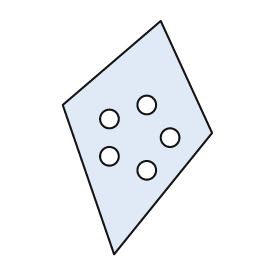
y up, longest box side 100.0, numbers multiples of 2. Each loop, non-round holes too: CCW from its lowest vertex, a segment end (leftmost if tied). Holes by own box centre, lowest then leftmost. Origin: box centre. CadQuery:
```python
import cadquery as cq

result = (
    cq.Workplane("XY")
    .moveTo(-10.0, -50.0)
    .lineTo(32.0, 2.0)
    .lineTo(10.0, 50.0)
    .lineTo(-32.0, 14.0)
    .close()
    .moveTo(4.0, -14.0)
    .circle(4.0)
    .moveTo(-12.0, -8.0)
    .circle(4.0)
    .moveTo(14.0, 0.0)
    .circle(4.0)
    .moveTo(-12.0, 8.0)
    .circle(4.0)
    .moveTo(4.0, 14.0)
    .circle(4.0)
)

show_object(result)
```